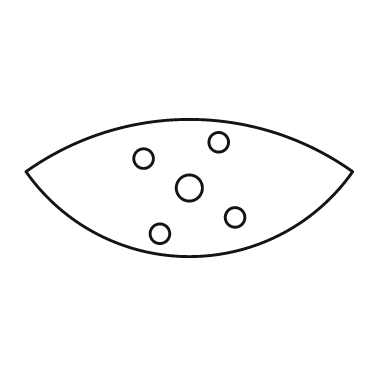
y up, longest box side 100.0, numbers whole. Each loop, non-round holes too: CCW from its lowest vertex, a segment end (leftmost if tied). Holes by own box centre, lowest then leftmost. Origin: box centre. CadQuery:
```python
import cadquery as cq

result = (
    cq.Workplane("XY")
    .moveTo(-50.0, 5.0)
    .threePointArc((0.0, -21.0), (50.0, 5.0))
    .threePointArc((0.0, 21.0), (-50.0, 5.0))
    .close()
    .moveTo(-9.0, -14.0)
    .circle(3.0)
    .moveTo(14.0, -9.0)
    .circle(3.0)
    .moveTo(0.0, 0.0)
    .circle(4.0)
    .moveTo(-14.0, 9.0)
    .circle(3.0)
    .moveTo(9.0, 14.0)
    .circle(3.0)
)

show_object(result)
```